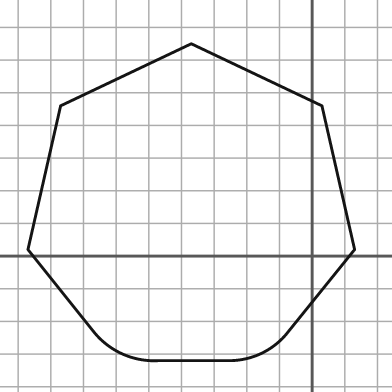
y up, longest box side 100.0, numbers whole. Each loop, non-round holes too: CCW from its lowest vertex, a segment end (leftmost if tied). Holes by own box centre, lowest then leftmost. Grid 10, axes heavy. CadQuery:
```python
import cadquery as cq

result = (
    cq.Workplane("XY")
    .moveTo(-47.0, -32.0)
    .lineTo(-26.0, -32.0)
    .threePointArc((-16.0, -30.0), (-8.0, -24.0))
    .lineTo(13.0, 2.0)
    .lineTo(3.0, 46.0)
    .lineTo(-37.0, 65.0)
    .lineTo(-77.0, 46.0)
    .lineTo(-87.0, 2.0)
    .lineTo(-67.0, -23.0)
    .threePointArc((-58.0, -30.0), (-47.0, -32.0))
    .close()
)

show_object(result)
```